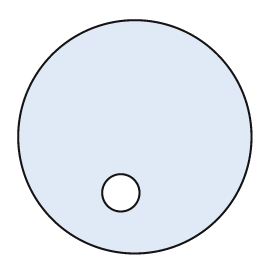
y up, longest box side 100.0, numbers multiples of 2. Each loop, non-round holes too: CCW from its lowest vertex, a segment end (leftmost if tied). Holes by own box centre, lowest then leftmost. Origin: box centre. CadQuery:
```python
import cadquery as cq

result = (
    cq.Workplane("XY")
    .moveTo(0.0, 0.0)
    .circle(50.0)
    .moveTo(-6.0, -24.0)
    .circle(8.0)
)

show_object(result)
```